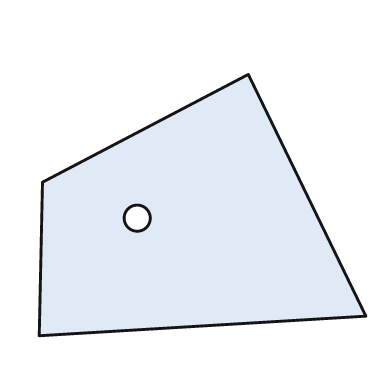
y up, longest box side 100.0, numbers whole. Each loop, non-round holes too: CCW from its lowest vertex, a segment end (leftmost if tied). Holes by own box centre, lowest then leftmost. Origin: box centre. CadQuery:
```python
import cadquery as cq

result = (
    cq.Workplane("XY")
    .moveTo(-50.0, -40.0)
    .lineTo(50.0, -34.0)
    .lineTo(14.0, 40.0)
    .lineTo(-49.0, 7.0)
    .close()
    .moveTo(-20.0, -4.0)
    .circle(4.0)
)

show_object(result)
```